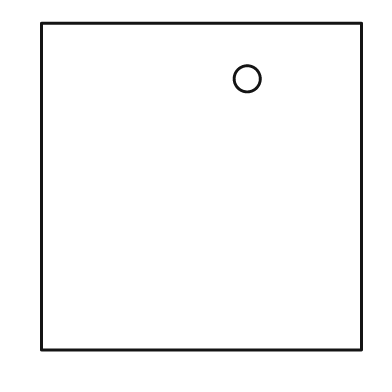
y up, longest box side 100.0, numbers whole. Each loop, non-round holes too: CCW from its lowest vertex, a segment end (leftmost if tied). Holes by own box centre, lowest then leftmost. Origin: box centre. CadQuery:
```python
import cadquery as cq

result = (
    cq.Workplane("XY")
    .moveTo(-49.0, -50.0)
    .lineTo(49.0, -50.0)
    .lineTo(49.0, 50.0)
    .lineTo(-49.0, 50.0)
    .close()
    .moveTo(14.0, 33.0)
    .circle(4.0)
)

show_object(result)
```